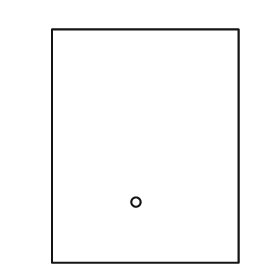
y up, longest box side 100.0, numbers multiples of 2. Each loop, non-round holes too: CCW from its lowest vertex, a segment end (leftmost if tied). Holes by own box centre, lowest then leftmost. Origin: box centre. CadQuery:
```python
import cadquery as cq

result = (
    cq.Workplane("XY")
    .moveTo(-40.0, -50.0)
    .lineTo(40.0, -50.0)
    .lineTo(40.0, 50.0)
    .lineTo(-40.0, 50.0)
    .close()
    .moveTo(-4.0, -24.0)
    .circle(2.0)
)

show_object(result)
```